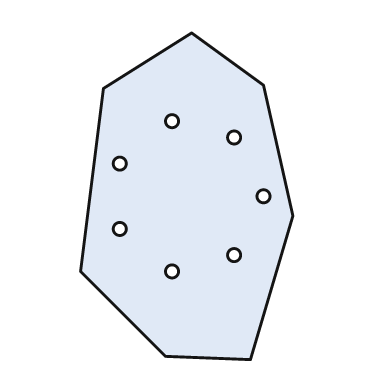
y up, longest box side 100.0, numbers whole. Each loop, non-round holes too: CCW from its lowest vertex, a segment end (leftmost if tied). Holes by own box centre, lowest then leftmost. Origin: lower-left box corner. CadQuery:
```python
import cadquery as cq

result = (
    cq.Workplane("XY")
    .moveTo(52.0, 0.0)
    .lineTo(65.0, 44.0)
    .lineTo(56.0, 84.0)
    .lineTo(34.0, 100.0)
    .lineTo(7.0, 83.0)
    .lineTo(0.0, 27.0)
    .lineTo(26.0, 1.0)
    .close()
    .moveTo(28.0, 27.0)
    .circle(2.0)
    .moveTo(47.0, 32.0)
    .circle(2.0)
    .moveTo(12.0, 40.0)
    .circle(2.0)
    .moveTo(56.0, 50.0)
    .circle(2.0)
    .moveTo(12.0, 60.0)
    .circle(2.0)
    .moveTo(47.0, 68.0)
    .circle(2.0)
    .moveTo(28.0, 73.0)
    .circle(2.0)
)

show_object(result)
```